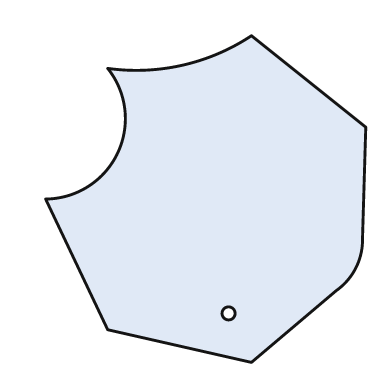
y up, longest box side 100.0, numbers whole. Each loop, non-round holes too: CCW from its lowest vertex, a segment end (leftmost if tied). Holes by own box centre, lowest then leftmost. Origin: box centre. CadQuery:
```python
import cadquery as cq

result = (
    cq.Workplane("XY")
    .moveTo(14.0, -50.0)
    .lineTo(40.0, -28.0)
    .threePointArc((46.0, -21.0), (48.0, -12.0))
    .lineTo(49.0, 22.0)
    .lineTo(14.0, 50.0)
    .threePointArc((-7.0, 41.0), (-30.0, 40.0))
    .threePointArc((-27.0, 14.0), (-49.0, 0.0))
    .lineTo(-30.0, -40.0)
    .close()
    .moveTo(7.0, -35.0)
    .circle(2.0)
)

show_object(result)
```